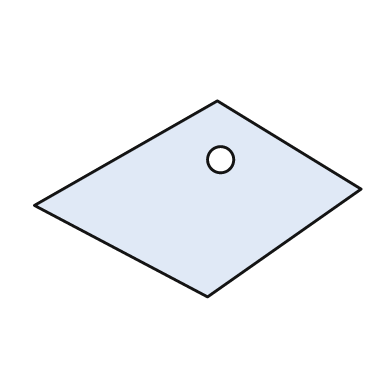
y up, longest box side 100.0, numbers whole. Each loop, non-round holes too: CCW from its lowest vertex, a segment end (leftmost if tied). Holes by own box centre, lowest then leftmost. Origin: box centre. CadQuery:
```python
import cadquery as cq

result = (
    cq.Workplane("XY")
    .moveTo(3.0, -30.0)
    .lineTo(50.0, 3.0)
    .lineTo(6.0, 30.0)
    .lineTo(-50.0, -2.0)
    .close()
    .moveTo(7.0, 12.0)
    .circle(4.0)
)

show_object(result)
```